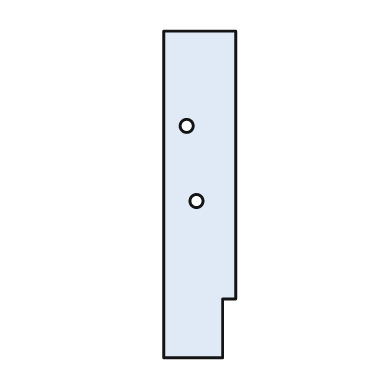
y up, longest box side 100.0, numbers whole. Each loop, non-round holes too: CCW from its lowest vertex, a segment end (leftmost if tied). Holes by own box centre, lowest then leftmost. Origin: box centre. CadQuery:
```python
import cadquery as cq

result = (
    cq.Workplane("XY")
    .moveTo(-11.0, -50.0)
    .lineTo(7.0, -50.0)
    .lineTo(7.0, -32.0)
    .lineTo(11.0, -32.0)
    .lineTo(11.0, 50.0)
    .lineTo(-11.0, 50.0)
    .close()
    .moveTo(-1.0, -2.0)
    .circle(2.0)
    .moveTo(-4.0, 21.0)
    .circle(2.0)
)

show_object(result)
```